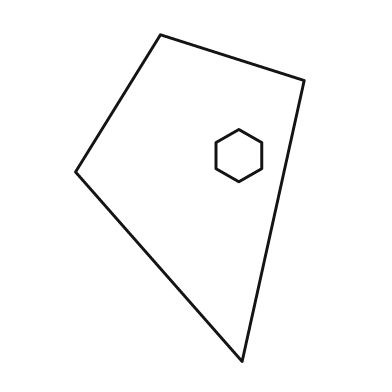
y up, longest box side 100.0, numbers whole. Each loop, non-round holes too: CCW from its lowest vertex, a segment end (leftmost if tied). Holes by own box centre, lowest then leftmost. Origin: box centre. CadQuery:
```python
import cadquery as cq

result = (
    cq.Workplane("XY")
    .moveTo(16.0, -50.0)
    .lineTo(35.0, 36.0)
    .lineTo(-9.0, 50.0)
    .lineTo(-35.0, 8.0)
    .close()
    .moveTo(15.0, 5.0)
    .lineTo(22.0, 9.0)
    .lineTo(22.0, 17.0)
    .lineTo(15.0, 21.0)
    .lineTo(8.0, 17.0)
    .lineTo(8.0, 9.0)
    .close()
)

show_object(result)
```